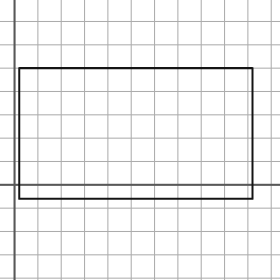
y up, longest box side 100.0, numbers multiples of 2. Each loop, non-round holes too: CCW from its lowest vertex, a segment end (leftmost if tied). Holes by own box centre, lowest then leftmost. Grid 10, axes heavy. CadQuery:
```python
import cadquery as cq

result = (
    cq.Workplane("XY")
    .moveTo(2.0, -6.0)
    .lineTo(102.0, -6.0)
    .lineTo(102.0, 50.0)
    .lineTo(2.0, 50.0)
    .close()
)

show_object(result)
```